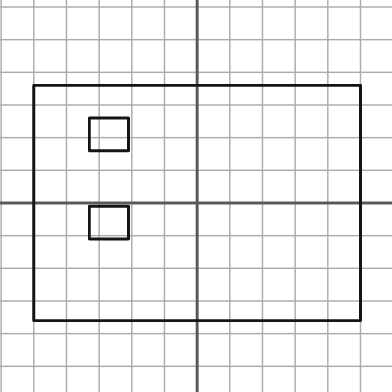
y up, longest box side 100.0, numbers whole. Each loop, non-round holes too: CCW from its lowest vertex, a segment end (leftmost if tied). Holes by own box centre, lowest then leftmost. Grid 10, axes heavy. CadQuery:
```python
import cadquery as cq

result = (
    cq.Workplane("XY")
    .moveTo(-50.0, -36.0)
    .lineTo(50.0, -36.0)
    .lineTo(50.0, 36.0)
    .lineTo(-50.0, 36.0)
    .close()
    .moveTo(-33.0, -11.0)
    .lineTo(-21.0, -11.0)
    .lineTo(-21.0, -1.0)
    .lineTo(-33.0, -1.0)
    .close()
    .moveTo(-33.0, 16.0)
    .lineTo(-21.0, 16.0)
    .lineTo(-21.0, 26.0)
    .lineTo(-33.0, 26.0)
    .close()
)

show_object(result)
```